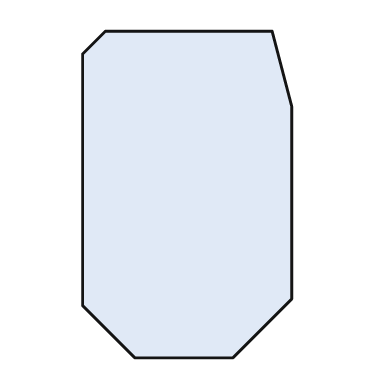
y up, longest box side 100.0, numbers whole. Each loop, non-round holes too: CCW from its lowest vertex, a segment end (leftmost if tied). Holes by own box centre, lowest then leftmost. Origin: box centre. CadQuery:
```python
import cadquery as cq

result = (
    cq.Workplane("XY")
    .moveTo(-16.0, -50.0)
    .lineTo(14.0, -50.0)
    .lineTo(32.0, -32.0)
    .lineTo(32.0, 27.0)
    .lineTo(26.0, 50.0)
    .lineTo(-25.0, 50.0)
    .lineTo(-32.0, 43.0)
    .lineTo(-32.0, -34.0)
    .close()
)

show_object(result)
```